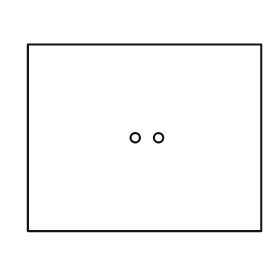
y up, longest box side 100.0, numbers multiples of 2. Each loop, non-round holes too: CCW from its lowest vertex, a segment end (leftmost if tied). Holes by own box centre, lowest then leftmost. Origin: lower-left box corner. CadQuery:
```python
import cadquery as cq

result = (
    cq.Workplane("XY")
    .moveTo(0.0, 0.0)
    .lineTo(100.0, 0.0)
    .lineTo(100.0, 80.0)
    .lineTo(0.0, 80.0)
    .close()
    .moveTo(46.0, 40.0)
    .circle(2.0)
    .moveTo(56.0, 40.0)
    .circle(2.0)
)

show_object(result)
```